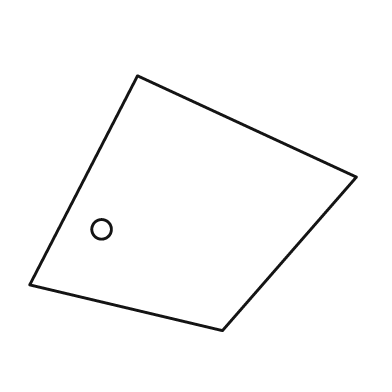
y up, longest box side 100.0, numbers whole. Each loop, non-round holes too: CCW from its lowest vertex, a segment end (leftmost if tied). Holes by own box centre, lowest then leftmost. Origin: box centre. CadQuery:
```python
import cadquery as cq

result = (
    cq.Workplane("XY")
    .moveTo(9.0, -39.0)
    .lineTo(50.0, 8.0)
    .lineTo(-17.0, 39.0)
    .lineTo(-50.0, -25.0)
    .close()
    .moveTo(-28.0, -8.0)
    .circle(3.0)
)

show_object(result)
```